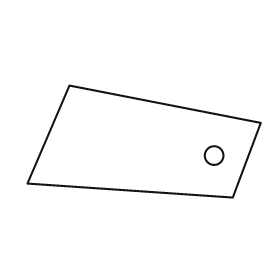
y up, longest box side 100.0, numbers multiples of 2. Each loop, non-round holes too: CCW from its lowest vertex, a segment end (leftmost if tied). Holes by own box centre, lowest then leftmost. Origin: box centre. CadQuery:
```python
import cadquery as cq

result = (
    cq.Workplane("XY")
    .moveTo(38.0, -24.0)
    .lineTo(50.0, 8.0)
    .lineTo(-32.0, 24.0)
    .lineTo(-50.0, -18.0)
    .close()
    .moveTo(30.0, -6.0)
    .circle(4.0)
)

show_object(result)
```